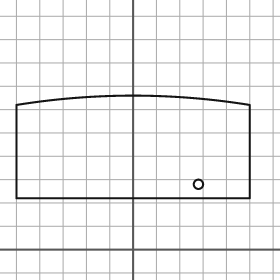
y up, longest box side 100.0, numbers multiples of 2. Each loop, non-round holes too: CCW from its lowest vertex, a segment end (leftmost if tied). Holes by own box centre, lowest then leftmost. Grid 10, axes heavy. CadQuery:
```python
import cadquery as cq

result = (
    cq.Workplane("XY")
    .moveTo(-50.0, 22.0)
    .lineTo(50.0, 22.0)
    .lineTo(50.0, 62.0)
    .threePointArc((0.0, 66.0), (-50.0, 62.0))
    .close()
    .moveTo(28.0, 28.0)
    .circle(2.0)
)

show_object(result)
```